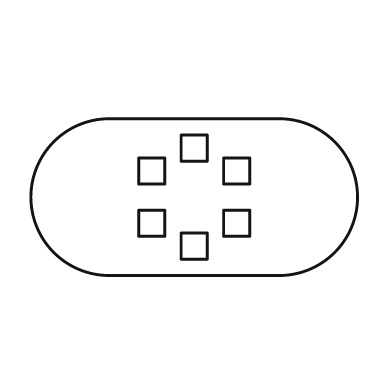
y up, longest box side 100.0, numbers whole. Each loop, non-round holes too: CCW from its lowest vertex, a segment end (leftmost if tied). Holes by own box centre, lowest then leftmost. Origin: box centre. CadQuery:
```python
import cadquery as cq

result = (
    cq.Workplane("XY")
    .moveTo(-26.0, -24.0)
    .lineTo(26.0, -24.0)
    .threePointArc((50.0, 0.0), (26.0, 24.0))
    .lineTo(-26.0, 24.0)
    .threePointArc((-50.0, 0.0), (-26.0, -24.0))
    .close()
    .moveTo(-4.0, -19.0)
    .lineTo(4.0, -19.0)
    .lineTo(4.0, -11.0)
    .lineTo(-4.0, -11.0)
    .close()
    .moveTo(-17.0, -12.0)
    .lineTo(-9.0, -12.0)
    .lineTo(-9.0, -4.0)
    .lineTo(-17.0, -4.0)
    .close()
    .moveTo(9.0, -12.0)
    .lineTo(17.0, -12.0)
    .lineTo(17.0, -4.0)
    .lineTo(9.0, -4.0)
    .close()
    .moveTo(-17.0, 4.0)
    .lineTo(-9.0, 4.0)
    .lineTo(-9.0, 12.0)
    .lineTo(-17.0, 12.0)
    .close()
    .moveTo(9.0, 4.0)
    .lineTo(17.0, 4.0)
    .lineTo(17.0, 12.0)
    .lineTo(9.0, 12.0)
    .close()
    .moveTo(-4.0, 11.0)
    .lineTo(4.0, 11.0)
    .lineTo(4.0, 19.0)
    .lineTo(-4.0, 19.0)
    .close()
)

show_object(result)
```